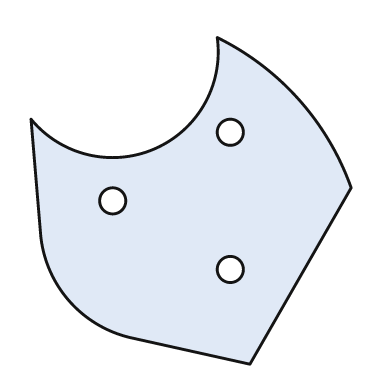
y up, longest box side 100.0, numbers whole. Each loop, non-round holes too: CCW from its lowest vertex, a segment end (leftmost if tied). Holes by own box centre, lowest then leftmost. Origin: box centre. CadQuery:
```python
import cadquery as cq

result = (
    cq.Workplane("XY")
    .moveTo(18.0, -50.0)
    .lineTo(49.0, 4.0)
    .threePointArc((33.0, 31.0), (8.0, 50.0))
    .threePointArc((-11.0, 16.0), (-49.0, 25.0))
    .lineTo(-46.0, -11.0)
    .threePointArc((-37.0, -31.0), (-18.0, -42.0))
    .close()
    .moveTo(12.0, -21.0)
    .circle(4.0)
    .moveTo(-24.0, 0.0)
    .circle(4.0)
    .moveTo(12.0, 21.0)
    .circle(4.0)
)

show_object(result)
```